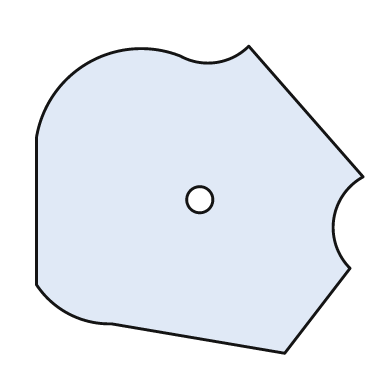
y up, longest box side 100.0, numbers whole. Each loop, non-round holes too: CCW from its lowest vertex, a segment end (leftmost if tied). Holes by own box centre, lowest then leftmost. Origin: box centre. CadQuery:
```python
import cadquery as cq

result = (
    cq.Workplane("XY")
    .moveTo(26.0, -47.0)
    .lineTo(46.0, -21.0)
    .threePointArc((41.0, -6.0), (50.0, 7.0))
    .lineTo(15.0, 47.0)
    .threePointArc((5.0, 42.0), (-6.0, 44.0))
    .threePointArc((-34.0, 42.0), (-50.0, 19.0))
    .lineTo(-50.0, -26.0)
    .threePointArc((-40.0, -35.0), (-27.0, -38.0))
    .close()
    .moveTo(0.0, 0.0)
    .circle(4.0)
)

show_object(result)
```